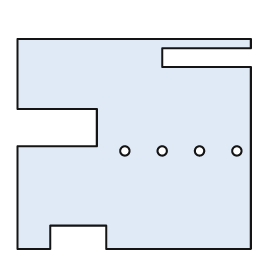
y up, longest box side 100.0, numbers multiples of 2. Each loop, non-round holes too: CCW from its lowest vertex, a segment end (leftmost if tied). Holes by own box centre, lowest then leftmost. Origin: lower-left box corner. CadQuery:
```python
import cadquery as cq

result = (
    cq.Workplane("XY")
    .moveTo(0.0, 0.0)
    .lineTo(14.0, 0.0)
    .lineTo(14.0, 10.0)
    .lineTo(38.0, 10.0)
    .lineTo(38.0, 0.0)
    .lineTo(100.0, 0.0)
    .lineTo(100.0, 78.0)
    .lineTo(62.0, 78.0)
    .lineTo(62.0, 86.0)
    .lineTo(100.0, 86.0)
    .lineTo(100.0, 90.0)
    .lineTo(0.0, 90.0)
    .lineTo(0.0, 60.0)
    .lineTo(34.0, 60.0)
    .lineTo(34.0, 44.0)
    .lineTo(0.0, 44.0)
    .close()
    .moveTo(46.0, 42.0)
    .circle(2.0)
    .moveTo(62.0, 42.0)
    .circle(2.0)
    .moveTo(78.0, 42.0)
    .circle(2.0)
    .moveTo(94.0, 42.0)
    .circle(2.0)
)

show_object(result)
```